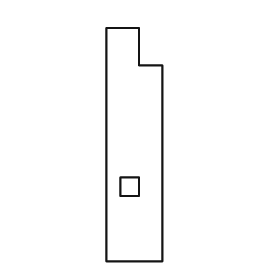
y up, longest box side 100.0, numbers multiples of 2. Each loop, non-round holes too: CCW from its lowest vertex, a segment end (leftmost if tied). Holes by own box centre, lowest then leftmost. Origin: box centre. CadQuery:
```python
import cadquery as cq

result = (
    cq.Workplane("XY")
    .moveTo(-12.0, -50.0)
    .lineTo(12.0, -50.0)
    .lineTo(12.0, 34.0)
    .lineTo(2.0, 34.0)
    .lineTo(2.0, 50.0)
    .lineTo(-12.0, 50.0)
    .close()
    .moveTo(-6.0, -22.0)
    .lineTo(2.0, -22.0)
    .lineTo(2.0, -14.0)
    .lineTo(-6.0, -14.0)
    .close()
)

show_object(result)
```